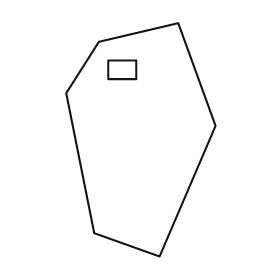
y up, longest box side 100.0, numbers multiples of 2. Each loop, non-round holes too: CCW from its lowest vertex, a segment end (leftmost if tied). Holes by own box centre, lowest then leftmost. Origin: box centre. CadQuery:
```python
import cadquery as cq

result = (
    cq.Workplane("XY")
    .moveTo(8.0, -50.0)
    .lineTo(32.0, 6.0)
    .lineTo(16.0, 50.0)
    .lineTo(-18.0, 42.0)
    .lineTo(-32.0, 20.0)
    .lineTo(-20.0, -40.0)
    .close()
    .moveTo(-14.0, 26.0)
    .lineTo(-2.0, 26.0)
    .lineTo(-2.0, 34.0)
    .lineTo(-14.0, 34.0)
    .close()
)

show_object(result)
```